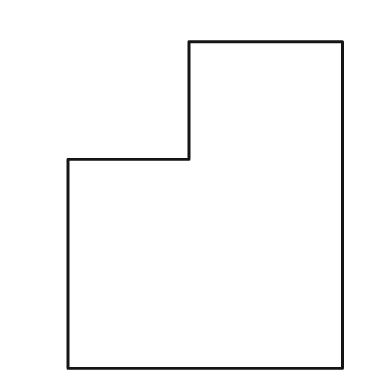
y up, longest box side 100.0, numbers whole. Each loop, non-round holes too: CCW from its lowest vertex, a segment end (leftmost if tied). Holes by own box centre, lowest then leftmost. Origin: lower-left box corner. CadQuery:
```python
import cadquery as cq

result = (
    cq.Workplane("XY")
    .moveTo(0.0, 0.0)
    .lineTo(84.0, 0.0)
    .lineTo(84.0, 100.0)
    .lineTo(37.0, 100.0)
    .lineTo(37.0, 64.0)
    .lineTo(0.0, 64.0)
    .close()
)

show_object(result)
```